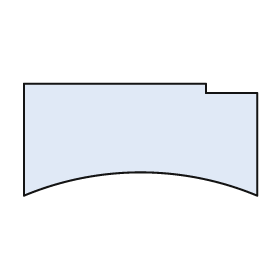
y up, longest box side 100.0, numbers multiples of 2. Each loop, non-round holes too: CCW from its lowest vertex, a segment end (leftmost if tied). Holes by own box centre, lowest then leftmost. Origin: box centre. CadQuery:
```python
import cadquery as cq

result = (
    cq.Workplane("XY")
    .moveTo(-50.0, -24.0)
    .threePointArc((0.0, -14.0), (50.0, -24.0))
    .lineTo(50.0, 20.0)
    .lineTo(28.0, 20.0)
    .lineTo(28.0, 24.0)
    .lineTo(-50.0, 24.0)
    .close()
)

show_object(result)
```